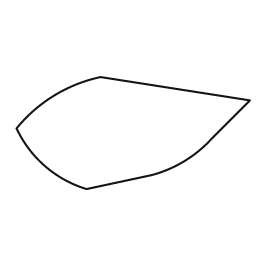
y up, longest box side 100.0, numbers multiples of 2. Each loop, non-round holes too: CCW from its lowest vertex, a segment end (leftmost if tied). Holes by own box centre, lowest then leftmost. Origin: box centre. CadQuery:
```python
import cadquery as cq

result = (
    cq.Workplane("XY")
    .moveTo(-20.0, -24.0)
    .lineTo(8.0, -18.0)
    .threePointArc((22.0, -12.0), (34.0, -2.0))
    .lineTo(50.0, 14.0)
    .lineTo(-14.0, 24.0)
    .threePointArc((-34.0, 16.0), (-50.0, 2.0))
    .threePointArc((-38.0, -14.0), (-20.0, -24.0))
    .close()
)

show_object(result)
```